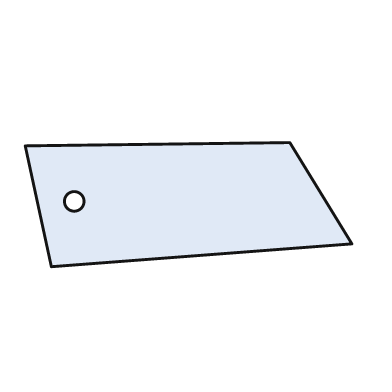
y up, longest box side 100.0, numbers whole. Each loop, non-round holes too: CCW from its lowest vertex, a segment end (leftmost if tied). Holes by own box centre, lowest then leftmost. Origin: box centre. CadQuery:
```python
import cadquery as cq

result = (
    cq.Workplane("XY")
    .moveTo(-42.0, -19.0)
    .lineTo(50.0, -12.0)
    .lineTo(31.0, 19.0)
    .lineTo(-50.0, 18.0)
    .close()
    .moveTo(-35.0, 1.0)
    .circle(3.0)
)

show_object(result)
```